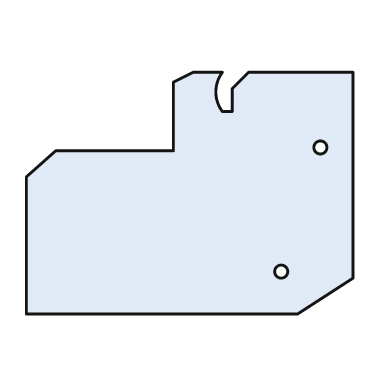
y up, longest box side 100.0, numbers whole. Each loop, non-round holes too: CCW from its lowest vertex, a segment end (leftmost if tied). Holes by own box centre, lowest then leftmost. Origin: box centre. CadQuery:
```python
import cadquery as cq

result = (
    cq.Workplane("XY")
    .moveTo(-50.0, -37.0)
    .lineTo(33.0, -37.0)
    .lineTo(50.0, -26.0)
    .lineTo(50.0, 37.0)
    .lineTo(18.0, 37.0)
    .lineTo(13.0, 32.0)
    .lineTo(13.0, 25.0)
    .lineTo(10.0, 25.0)
    .threePointArc((8.0, 31.0), (10.0, 37.0))
    .lineTo(1.0, 37.0)
    .lineTo(-5.0, 34.0)
    .lineTo(-5.0, 13.0)
    .lineTo(-41.0, 13.0)
    .lineTo(-50.0, 5.0)
    .close()
    .moveTo(28.0, -24.0)
    .circle(2.0)
    .moveTo(40.0, 14.0)
    .circle(2.0)
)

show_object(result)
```